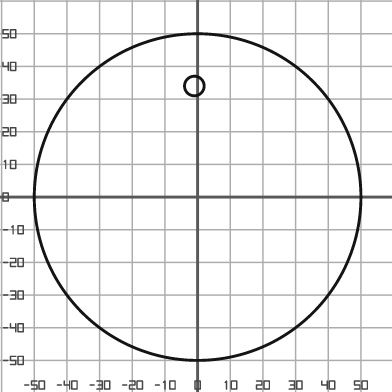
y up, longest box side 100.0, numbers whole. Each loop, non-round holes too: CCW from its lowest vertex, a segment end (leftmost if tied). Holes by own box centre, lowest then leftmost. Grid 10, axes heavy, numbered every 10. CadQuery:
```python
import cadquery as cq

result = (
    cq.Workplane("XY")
    .moveTo(0.0, 0.0)
    .circle(50.0)
    .moveTo(-1.0, 34.0)
    .circle(3.0)
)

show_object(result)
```